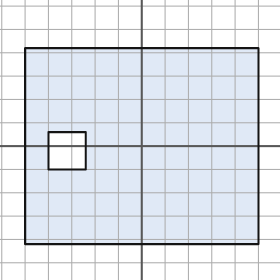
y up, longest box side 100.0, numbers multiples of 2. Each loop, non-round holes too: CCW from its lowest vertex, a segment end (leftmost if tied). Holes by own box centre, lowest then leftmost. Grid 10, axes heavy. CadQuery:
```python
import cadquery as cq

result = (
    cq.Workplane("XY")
    .moveTo(-50.0, -42.0)
    .lineTo(50.0, -42.0)
    .lineTo(50.0, 42.0)
    .lineTo(-50.0, 42.0)
    .close()
    .moveTo(-40.0, -10.0)
    .lineTo(-24.0, -10.0)
    .lineTo(-24.0, 6.0)
    .lineTo(-40.0, 6.0)
    .close()
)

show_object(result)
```